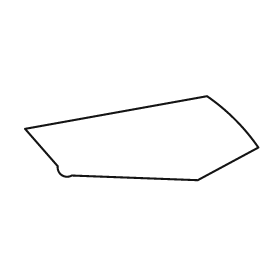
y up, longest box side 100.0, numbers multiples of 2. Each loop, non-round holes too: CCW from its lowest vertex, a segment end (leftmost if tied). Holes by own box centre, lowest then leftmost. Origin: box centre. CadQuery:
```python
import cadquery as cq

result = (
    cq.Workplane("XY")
    .moveTo(24.0, -18.0)
    .lineTo(50.0, -4.0)
    .threePointArc((40.0, 8.0), (28.0, 18.0))
    .lineTo(-50.0, 4.0)
    .lineTo(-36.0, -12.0)
    .threePointArc((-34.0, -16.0), (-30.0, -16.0))
    .close()
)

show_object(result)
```